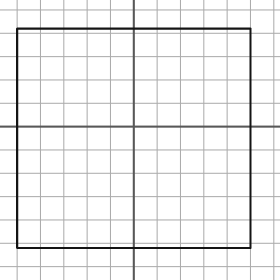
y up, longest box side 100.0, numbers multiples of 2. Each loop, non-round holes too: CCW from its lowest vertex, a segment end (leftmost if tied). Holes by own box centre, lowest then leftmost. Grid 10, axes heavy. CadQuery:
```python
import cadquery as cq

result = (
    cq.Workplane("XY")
    .moveTo(-50.0, -52.0)
    .lineTo(50.0, -52.0)
    .lineTo(50.0, 42.0)
    .lineTo(-50.0, 42.0)
    .close()
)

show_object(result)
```